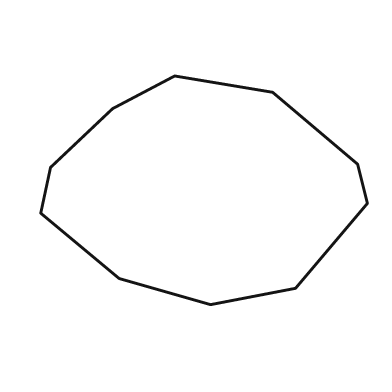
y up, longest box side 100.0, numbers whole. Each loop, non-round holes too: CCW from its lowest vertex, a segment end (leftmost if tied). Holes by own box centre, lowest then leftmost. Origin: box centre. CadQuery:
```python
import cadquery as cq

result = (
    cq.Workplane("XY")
    .moveTo(2.0, -35.0)
    .lineTo(28.0, -30.0)
    .lineTo(50.0, -4.0)
    .lineTo(47.0, 8.0)
    .lineTo(21.0, 30.0)
    .lineTo(-9.0, 35.0)
    .lineTo(-28.0, 25.0)
    .lineTo(-47.0, 7.0)
    .lineTo(-50.0, -7.0)
    .lineTo(-26.0, -27.0)
    .close()
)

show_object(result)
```